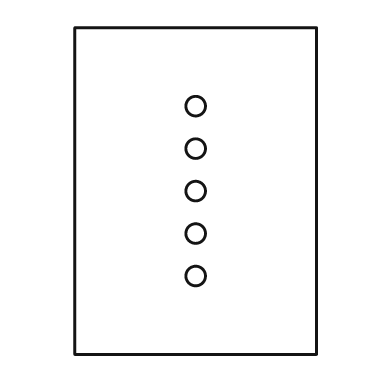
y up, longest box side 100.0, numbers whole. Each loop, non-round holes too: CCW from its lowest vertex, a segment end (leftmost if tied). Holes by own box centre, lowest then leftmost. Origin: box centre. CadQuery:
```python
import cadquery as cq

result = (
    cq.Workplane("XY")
    .moveTo(-37.0, -50.0)
    .lineTo(37.0, -50.0)
    .lineTo(37.0, 50.0)
    .lineTo(-37.0, 50.0)
    .close()
    .moveTo(0.0, -26.0)
    .circle(3.0)
    .moveTo(0.0, -13.0)
    .circle(3.0)
    .moveTo(0.0, 0.0)
    .circle(3.0)
    .moveTo(0.0, 13.0)
    .circle(3.0)
    .moveTo(0.0, 26.0)
    .circle(3.0)
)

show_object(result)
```